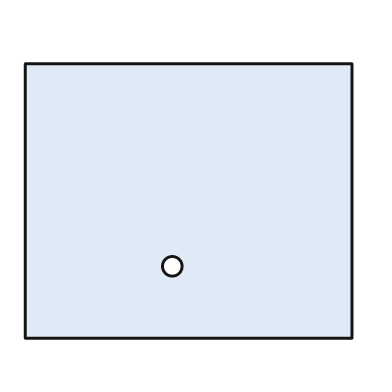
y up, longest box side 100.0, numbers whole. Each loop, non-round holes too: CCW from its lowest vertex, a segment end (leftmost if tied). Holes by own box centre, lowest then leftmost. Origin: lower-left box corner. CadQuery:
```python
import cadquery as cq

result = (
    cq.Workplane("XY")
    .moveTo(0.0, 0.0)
    .lineTo(100.0, 0.0)
    .lineTo(100.0, 84.0)
    .lineTo(0.0, 84.0)
    .close()
    .moveTo(45.0, 22.0)
    .circle(3.0)
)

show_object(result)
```